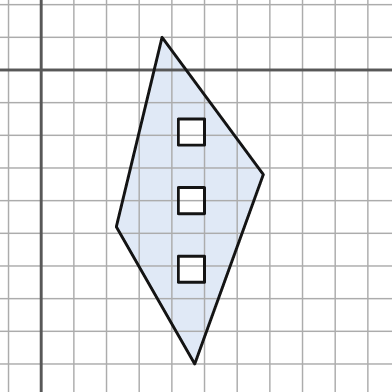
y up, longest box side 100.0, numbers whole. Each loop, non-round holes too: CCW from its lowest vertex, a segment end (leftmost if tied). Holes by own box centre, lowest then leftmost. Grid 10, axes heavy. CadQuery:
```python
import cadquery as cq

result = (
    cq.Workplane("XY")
    .moveTo(47.0, -90.0)
    .lineTo(68.0, -32.0)
    .lineTo(37.0, 10.0)
    .lineTo(23.0, -48.0)
    .close()
    .moveTo(42.0, -65.0)
    .lineTo(50.0, -65.0)
    .lineTo(50.0, -57.0)
    .lineTo(42.0, -57.0)
    .close()
    .moveTo(42.0, -44.0)
    .lineTo(50.0, -44.0)
    .lineTo(50.0, -36.0)
    .lineTo(42.0, -36.0)
    .close()
    .moveTo(42.0, -23.0)
    .lineTo(50.0, -23.0)
    .lineTo(50.0, -15.0)
    .lineTo(42.0, -15.0)
    .close()
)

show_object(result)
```